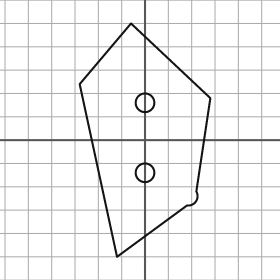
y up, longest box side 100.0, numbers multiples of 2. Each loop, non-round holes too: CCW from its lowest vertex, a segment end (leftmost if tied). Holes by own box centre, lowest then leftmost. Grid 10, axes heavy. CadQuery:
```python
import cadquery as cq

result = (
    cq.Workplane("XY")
    .moveTo(-12.0, -50.0)
    .lineTo(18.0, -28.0)
    .threePointArc((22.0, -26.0), (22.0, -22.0))
    .lineTo(28.0, 18.0)
    .lineTo(-6.0, 50.0)
    .lineTo(-28.0, 24.0)
    .close()
    .moveTo(0.0, -14.0)
    .circle(4.0)
    .moveTo(0.0, 16.0)
    .circle(4.0)
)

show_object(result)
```